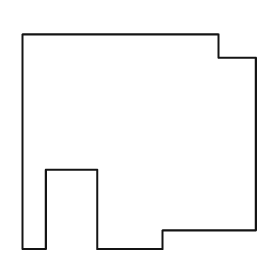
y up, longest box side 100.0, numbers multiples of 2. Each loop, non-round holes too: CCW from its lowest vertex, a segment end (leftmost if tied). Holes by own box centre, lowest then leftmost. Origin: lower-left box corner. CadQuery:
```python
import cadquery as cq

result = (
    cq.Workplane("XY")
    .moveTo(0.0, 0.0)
    .lineTo(10.0, 0.0)
    .lineTo(10.0, 34.0)
    .lineTo(32.0, 34.0)
    .lineTo(32.0, 0.0)
    .lineTo(60.0, 0.0)
    .lineTo(60.0, 8.0)
    .lineTo(100.0, 8.0)
    .lineTo(100.0, 82.0)
    .lineTo(84.0, 82.0)
    .lineTo(84.0, 92.0)
    .lineTo(0.0, 92.0)
    .close()
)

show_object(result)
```